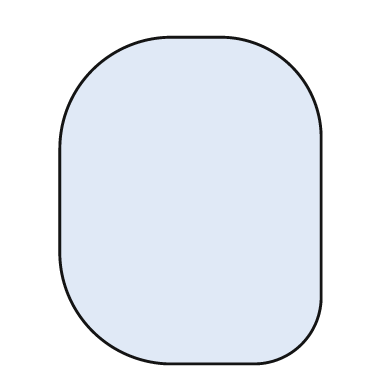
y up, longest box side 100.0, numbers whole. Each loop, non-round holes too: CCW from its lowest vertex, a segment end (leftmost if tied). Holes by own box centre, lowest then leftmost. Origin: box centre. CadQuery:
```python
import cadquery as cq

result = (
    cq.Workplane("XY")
    .moveTo(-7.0, -50.0)
    .lineTo(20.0, -50.0)
    .threePointArc((34.0, -44.0), (40.0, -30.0))
    .lineTo(40.0, 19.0)
    .threePointArc((31.0, 41.0), (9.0, 50.0))
    .lineTo(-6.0, 50.0)
    .threePointArc((-30.0, 40.0), (-40.0, 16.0))
    .lineTo(-40.0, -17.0)
    .threePointArc((-30.0, -40.0), (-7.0, -50.0))
    .close()
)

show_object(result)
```